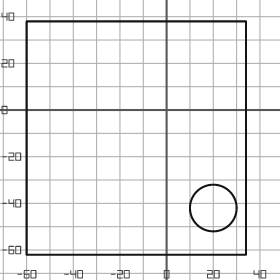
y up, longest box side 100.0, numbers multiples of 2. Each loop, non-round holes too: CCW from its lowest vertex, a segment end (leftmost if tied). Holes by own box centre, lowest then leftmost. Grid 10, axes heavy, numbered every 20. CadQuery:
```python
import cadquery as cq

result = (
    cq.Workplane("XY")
    .moveTo(-60.0, -62.0)
    .lineTo(34.0, -62.0)
    .lineTo(34.0, 38.0)
    .lineTo(-60.0, 38.0)
    .close()
    .moveTo(20.0, -42.0)
    .circle(10.0)
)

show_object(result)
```